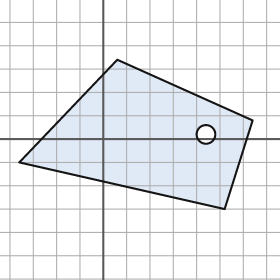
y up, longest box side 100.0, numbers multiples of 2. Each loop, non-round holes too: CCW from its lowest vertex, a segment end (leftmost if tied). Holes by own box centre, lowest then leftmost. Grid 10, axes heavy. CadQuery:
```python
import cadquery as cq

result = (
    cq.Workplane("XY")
    .moveTo(52.0, -30.0)
    .lineTo(64.0, 8.0)
    .lineTo(6.0, 34.0)
    .lineTo(-36.0, -10.0)
    .close()
    .moveTo(44.0, 2.0)
    .circle(4.0)
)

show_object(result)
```